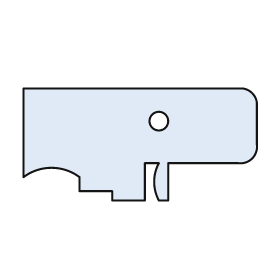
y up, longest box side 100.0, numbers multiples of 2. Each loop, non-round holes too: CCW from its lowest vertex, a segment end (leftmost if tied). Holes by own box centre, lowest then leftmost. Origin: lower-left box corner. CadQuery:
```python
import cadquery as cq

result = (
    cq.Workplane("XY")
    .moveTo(38.0, 0.0)
    .lineTo(52.0, 0.0)
    .lineTo(52.0, 16.0)
    .lineTo(58.0, 16.0)
    .threePointArc((56.0, 8.0), (58.0, 0.0))
    .lineTo(62.0, 0.0)
    .lineTo(62.0, 16.0)
    .lineTo(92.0, 16.0)
    .threePointArc((98.0, 18.0), (100.0, 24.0))
    .lineTo(100.0, 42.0)
    .threePointArc((98.0, 46.0), (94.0, 48.0))
    .lineTo(0.0, 48.0)
    .lineTo(0.0, 10.0)
    .threePointArc((12.0, 14.0), (24.0, 10.0))
    .lineTo(24.0, 4.0)
    .lineTo(38.0, 4.0)
    .close()
    .moveTo(58.0, 34.0)
    .circle(4.0)
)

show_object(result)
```